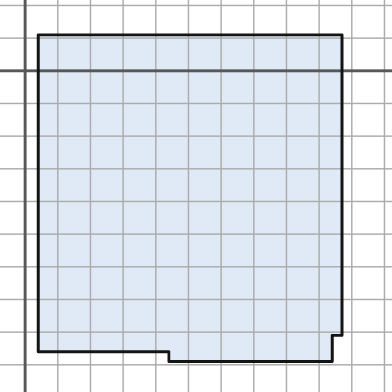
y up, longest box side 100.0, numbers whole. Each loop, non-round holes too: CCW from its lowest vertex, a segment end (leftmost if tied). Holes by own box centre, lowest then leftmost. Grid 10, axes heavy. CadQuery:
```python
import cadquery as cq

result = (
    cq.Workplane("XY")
    .moveTo(44.0, -89.0)
    .lineTo(94.0, -89.0)
    .lineTo(94.0, -81.0)
    .lineTo(97.0, -81.0)
    .lineTo(97.0, 11.0)
    .lineTo(4.0, 11.0)
    .lineTo(4.0, -86.0)
    .lineTo(44.0, -86.0)
    .close()
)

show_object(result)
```